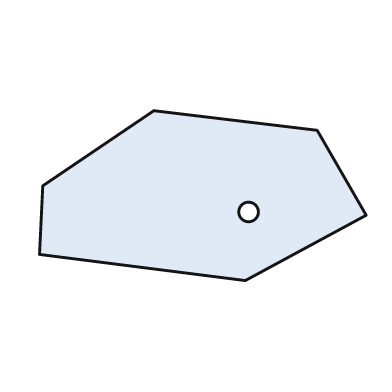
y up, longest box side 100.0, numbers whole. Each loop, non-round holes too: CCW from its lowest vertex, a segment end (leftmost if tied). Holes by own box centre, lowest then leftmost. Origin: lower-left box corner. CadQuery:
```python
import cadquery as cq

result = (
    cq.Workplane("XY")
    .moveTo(63.0, 0.0)
    .lineTo(100.0, 20.0)
    .lineTo(85.0, 46.0)
    .lineTo(35.0, 52.0)
    .lineTo(1.0, 29.0)
    .lineTo(0.0, 8.0)
    .close()
    .moveTo(64.0, 21.0)
    .circle(3.0)
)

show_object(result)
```